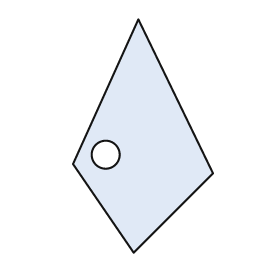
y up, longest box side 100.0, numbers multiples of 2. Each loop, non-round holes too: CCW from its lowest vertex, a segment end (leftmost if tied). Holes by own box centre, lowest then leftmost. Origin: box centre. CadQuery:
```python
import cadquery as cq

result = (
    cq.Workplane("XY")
    .moveTo(-4.0, -50.0)
    .lineTo(30.0, -16.0)
    .lineTo(-2.0, 50.0)
    .lineTo(-30.0, -12.0)
    .close()
    .moveTo(-16.0, -8.0)
    .circle(6.0)
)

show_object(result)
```